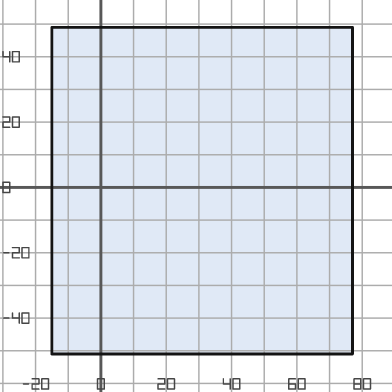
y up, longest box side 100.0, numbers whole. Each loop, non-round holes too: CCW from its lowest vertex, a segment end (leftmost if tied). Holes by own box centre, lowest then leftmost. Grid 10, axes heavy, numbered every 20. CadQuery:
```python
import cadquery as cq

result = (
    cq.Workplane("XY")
    .moveTo(-15.0, -51.0)
    .lineTo(77.0, -51.0)
    .lineTo(77.0, 49.0)
    .lineTo(-15.0, 49.0)
    .close()
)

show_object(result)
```